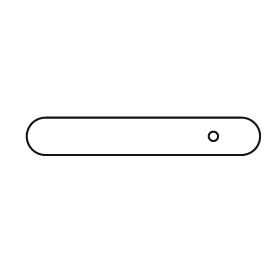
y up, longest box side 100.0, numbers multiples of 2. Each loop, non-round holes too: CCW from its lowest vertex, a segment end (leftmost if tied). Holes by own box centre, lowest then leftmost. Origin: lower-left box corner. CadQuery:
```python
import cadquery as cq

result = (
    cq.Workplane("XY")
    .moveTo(8.0, 0.0)
    .lineTo(92.0, 0.0)
    .threePointArc((100.0, 8.0), (92.0, 16.0))
    .lineTo(8.0, 16.0)
    .threePointArc((0.0, 8.0), (8.0, 0.0))
    .close()
    .moveTo(80.0, 8.0)
    .circle(2.0)
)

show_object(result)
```